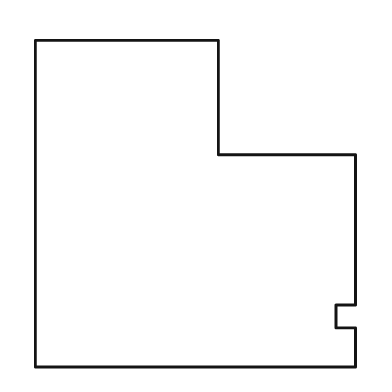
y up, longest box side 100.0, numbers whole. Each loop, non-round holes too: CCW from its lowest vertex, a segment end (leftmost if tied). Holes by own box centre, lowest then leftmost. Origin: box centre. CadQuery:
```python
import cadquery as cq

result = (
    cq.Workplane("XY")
    .moveTo(-49.0, -50.0)
    .lineTo(49.0, -50.0)
    .lineTo(49.0, -38.0)
    .lineTo(43.0, -38.0)
    .lineTo(43.0, -31.0)
    .lineTo(49.0, -31.0)
    .lineTo(49.0, 15.0)
    .lineTo(7.0, 15.0)
    .lineTo(7.0, 50.0)
    .lineTo(-49.0, 50.0)
    .close()
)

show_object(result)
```